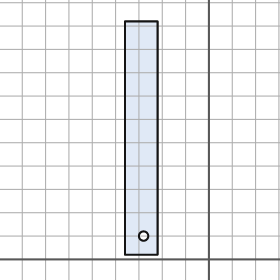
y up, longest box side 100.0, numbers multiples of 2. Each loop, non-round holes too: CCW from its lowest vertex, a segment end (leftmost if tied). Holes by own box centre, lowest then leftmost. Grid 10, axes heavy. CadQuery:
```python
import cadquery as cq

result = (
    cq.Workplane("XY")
    .moveTo(-36.0, 2.0)
    .lineTo(-22.0, 2.0)
    .lineTo(-22.0, 102.0)
    .lineTo(-36.0, 102.0)
    .close()
    .moveTo(-28.0, 10.0)
    .circle(2.0)
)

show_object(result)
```